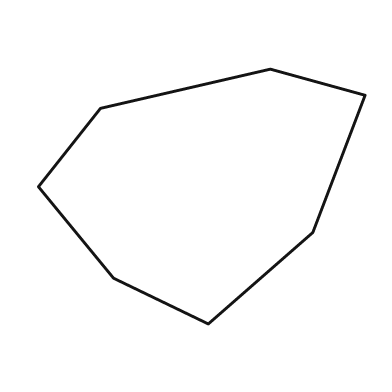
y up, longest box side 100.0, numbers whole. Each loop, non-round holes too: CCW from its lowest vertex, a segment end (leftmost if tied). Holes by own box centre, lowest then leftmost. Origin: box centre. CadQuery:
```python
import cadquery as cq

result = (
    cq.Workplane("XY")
    .moveTo(2.0, -39.0)
    .lineTo(34.0, -11.0)
    .lineTo(50.0, 31.0)
    .lineTo(21.0, 39.0)
    .lineTo(-31.0, 27.0)
    .lineTo(-50.0, 3.0)
    .lineTo(-27.0, -25.0)
    .close()
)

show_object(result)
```